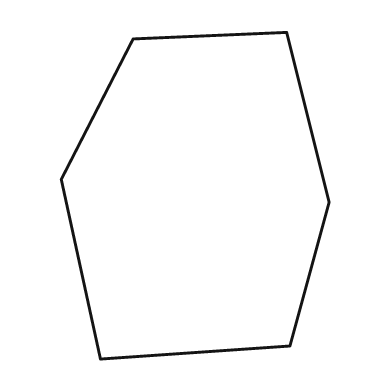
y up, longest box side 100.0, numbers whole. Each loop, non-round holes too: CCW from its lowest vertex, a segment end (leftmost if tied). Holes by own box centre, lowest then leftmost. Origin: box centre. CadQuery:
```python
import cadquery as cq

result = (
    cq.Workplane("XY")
    .moveTo(-29.0, -50.0)
    .lineTo(29.0, -46.0)
    .lineTo(41.0, -2.0)
    .lineTo(28.0, 50.0)
    .lineTo(-19.0, 48.0)
    .lineTo(-41.0, 5.0)
    .close()
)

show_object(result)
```